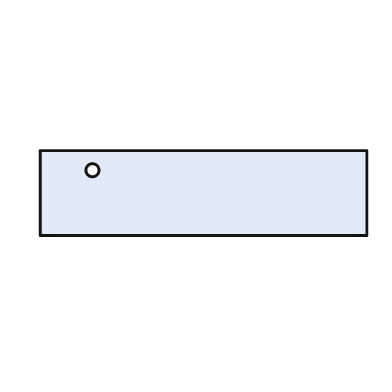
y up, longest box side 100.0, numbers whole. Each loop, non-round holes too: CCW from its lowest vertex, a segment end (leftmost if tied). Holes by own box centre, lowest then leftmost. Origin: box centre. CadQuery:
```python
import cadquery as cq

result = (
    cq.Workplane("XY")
    .moveTo(-50.0, -13.0)
    .lineTo(50.0, -13.0)
    .lineTo(50.0, 13.0)
    .lineTo(-50.0, 13.0)
    .close()
    .moveTo(-34.0, 7.0)
    .circle(2.0)
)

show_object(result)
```